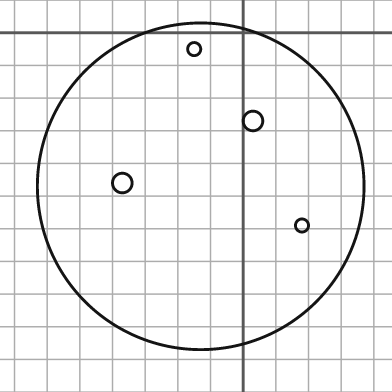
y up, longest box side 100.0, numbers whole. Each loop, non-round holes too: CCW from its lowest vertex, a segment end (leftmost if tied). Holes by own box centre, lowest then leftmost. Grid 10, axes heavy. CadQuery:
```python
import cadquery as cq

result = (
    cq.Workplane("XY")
    .moveTo(-13.0, -47.0)
    .circle(50.0)
    .moveTo(18.0, -59.0)
    .circle(2.0)
    .moveTo(-37.0, -46.0)
    .circle(3.0)
    .moveTo(3.0, -27.0)
    .circle(3.0)
    .moveTo(-15.0, -5.0)
    .circle(2.0)
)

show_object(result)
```